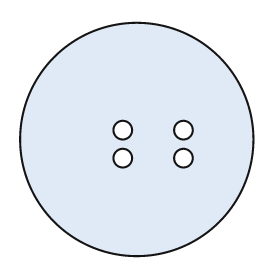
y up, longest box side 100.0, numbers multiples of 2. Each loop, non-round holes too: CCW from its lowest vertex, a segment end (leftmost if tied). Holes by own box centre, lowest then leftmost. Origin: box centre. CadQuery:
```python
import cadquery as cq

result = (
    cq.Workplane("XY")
    .moveTo(0.0, 0.0)
    .circle(50.0)
    .moveTo(-6.0, -8.0)
    .circle(4.0)
    .moveTo(20.0, -8.0)
    .circle(4.0)
    .moveTo(-6.0, 4.0)
    .circle(4.0)
    .moveTo(20.0, 4.0)
    .circle(4.0)
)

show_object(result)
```